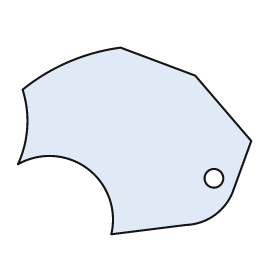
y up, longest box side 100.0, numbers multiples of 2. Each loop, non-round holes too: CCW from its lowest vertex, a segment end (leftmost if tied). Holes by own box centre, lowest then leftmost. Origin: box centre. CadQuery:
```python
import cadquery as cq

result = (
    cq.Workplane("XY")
    .moveTo(-10.0, -40.0)
    .lineTo(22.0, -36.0)
    .threePointArc((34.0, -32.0), (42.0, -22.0))
    .lineTo(50.0, 0.0)
    .lineTo(26.0, 28.0)
    .lineTo(-6.0, 40.0)
    .threePointArc((-28.0, 34.0), (-48.0, 22.0))
    .threePointArc((-46.0, 6.0), (-50.0, -10.0))
    .threePointArc((-20.0, -12.0), (-10.0, -40.0))
    .close()
    .moveTo(34.0, -16.0)
    .circle(4.0)
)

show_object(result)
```